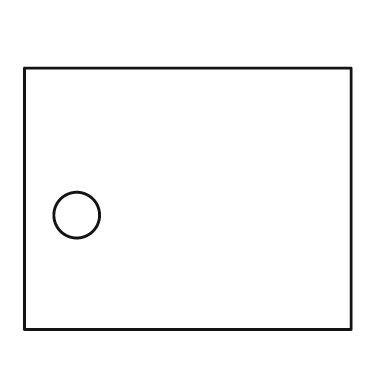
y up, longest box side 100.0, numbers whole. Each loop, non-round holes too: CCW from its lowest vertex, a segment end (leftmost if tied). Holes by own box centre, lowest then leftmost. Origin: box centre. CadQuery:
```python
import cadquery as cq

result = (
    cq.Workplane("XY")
    .moveTo(-50.0, -40.0)
    .lineTo(50.0, -40.0)
    .lineTo(50.0, 40.0)
    .lineTo(-50.0, 40.0)
    .close()
    .moveTo(-34.0, -5.0)
    .circle(7.0)
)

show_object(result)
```